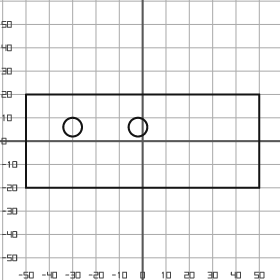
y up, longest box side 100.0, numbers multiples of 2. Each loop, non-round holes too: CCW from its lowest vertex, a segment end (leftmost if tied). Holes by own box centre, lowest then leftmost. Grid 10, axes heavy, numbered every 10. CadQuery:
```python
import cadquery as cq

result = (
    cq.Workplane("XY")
    .moveTo(-50.0, -20.0)
    .lineTo(50.0, -20.0)
    .lineTo(50.0, 20.0)
    .lineTo(-50.0, 20.0)
    .close()
    .moveTo(-30.0, 6.0)
    .circle(4.0)
    .moveTo(-2.0, 6.0)
    .circle(4.0)
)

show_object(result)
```